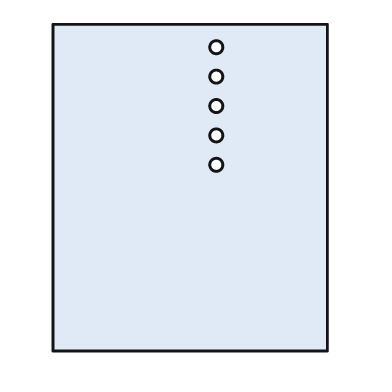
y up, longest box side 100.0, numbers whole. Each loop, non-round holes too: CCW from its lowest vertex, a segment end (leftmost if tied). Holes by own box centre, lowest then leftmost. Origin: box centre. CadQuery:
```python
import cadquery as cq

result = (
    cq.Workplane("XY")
    .moveTo(-42.0, -50.0)
    .lineTo(42.0, -50.0)
    .lineTo(42.0, 50.0)
    .lineTo(-42.0, 50.0)
    .close()
    .moveTo(8.0, 7.0)
    .circle(2.0)
    .moveTo(8.0, 16.0)
    .circle(2.0)
    .moveTo(8.0, 25.0)
    .circle(2.0)
    .moveTo(8.0, 34.0)
    .circle(2.0)
    .moveTo(8.0, 43.0)
    .circle(2.0)
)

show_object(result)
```